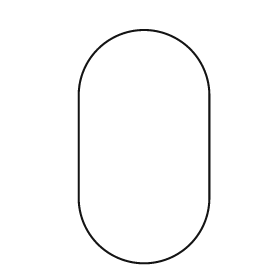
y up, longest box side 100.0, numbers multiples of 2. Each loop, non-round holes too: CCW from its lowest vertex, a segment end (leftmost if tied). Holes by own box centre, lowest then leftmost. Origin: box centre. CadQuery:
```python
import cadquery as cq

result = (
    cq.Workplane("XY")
    .moveTo(-28.0, -22.0)
    .threePointArc((0.0, -50.0), (28.0, -22.0))
    .lineTo(28.0, 22.0)
    .threePointArc((0.0, 50.0), (-28.0, 22.0))
    .close()
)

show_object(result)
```